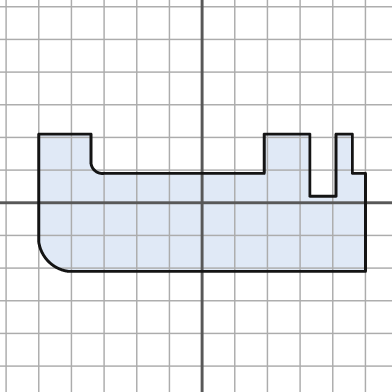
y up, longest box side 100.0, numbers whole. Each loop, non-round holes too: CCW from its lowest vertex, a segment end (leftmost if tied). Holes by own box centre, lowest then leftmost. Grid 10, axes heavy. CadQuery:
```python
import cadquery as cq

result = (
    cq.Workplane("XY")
    .moveTo(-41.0, -21.0)
    .lineTo(50.0, -21.0)
    .lineTo(50.0, 9.0)
    .lineTo(46.0, 9.0)
    .lineTo(46.0, 21.0)
    .lineTo(41.0, 21.0)
    .lineTo(41.0, 2.0)
    .lineTo(33.0, 2.0)
    .lineTo(33.0, 21.0)
    .lineTo(19.0, 21.0)
    .lineTo(19.0, 9.0)
    .lineTo(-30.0, 9.0)
    .threePointArc((-33.0, 10.0), (-34.0, 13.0))
    .lineTo(-34.0, 21.0)
    .lineTo(-50.0, 21.0)
    .lineTo(-50.0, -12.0)
    .threePointArc((-47.0, -18.0), (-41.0, -21.0))
    .close()
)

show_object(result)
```